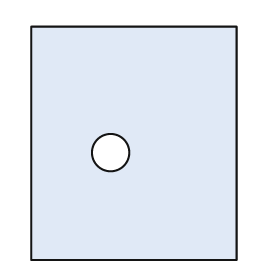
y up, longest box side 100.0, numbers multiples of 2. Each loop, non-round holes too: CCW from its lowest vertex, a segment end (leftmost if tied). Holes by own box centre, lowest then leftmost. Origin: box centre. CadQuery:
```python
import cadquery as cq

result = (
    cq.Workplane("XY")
    .moveTo(-44.0, -50.0)
    .lineTo(44.0, -50.0)
    .lineTo(44.0, 50.0)
    .lineTo(-44.0, 50.0)
    .close()
    .moveTo(-10.0, -4.0)
    .circle(8.0)
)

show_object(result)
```